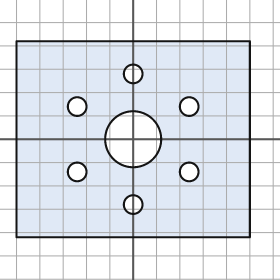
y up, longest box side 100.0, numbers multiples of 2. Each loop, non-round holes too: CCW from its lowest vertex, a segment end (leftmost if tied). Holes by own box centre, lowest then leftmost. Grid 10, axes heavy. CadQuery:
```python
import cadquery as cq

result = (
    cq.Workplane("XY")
    .moveTo(-50.0, -42.0)
    .lineTo(50.0, -42.0)
    .lineTo(50.0, 42.0)
    .lineTo(-50.0, 42.0)
    .close()
    .moveTo(0.0, -28.0)
    .circle(4.0)
    .moveTo(-24.0, -14.0)
    .circle(4.0)
    .moveTo(24.0, -14.0)
    .circle(4.0)
    .moveTo(0.0, 0.0)
    .circle(12.0)
    .moveTo(-24.0, 14.0)
    .circle(4.0)
    .moveTo(24.0, 14.0)
    .circle(4.0)
    .moveTo(0.0, 28.0)
    .circle(4.0)
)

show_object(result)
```